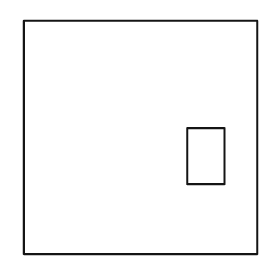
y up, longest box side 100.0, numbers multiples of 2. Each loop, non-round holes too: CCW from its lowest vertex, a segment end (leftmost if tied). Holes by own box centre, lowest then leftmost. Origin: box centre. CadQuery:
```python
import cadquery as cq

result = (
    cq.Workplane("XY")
    .moveTo(-50.0, -50.0)
    .lineTo(50.0, -50.0)
    .lineTo(50.0, 50.0)
    .lineTo(-50.0, 50.0)
    .close()
    .moveTo(20.0, -20.0)
    .lineTo(36.0, -20.0)
    .lineTo(36.0, 4.0)
    .lineTo(20.0, 4.0)
    .close()
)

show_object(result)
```